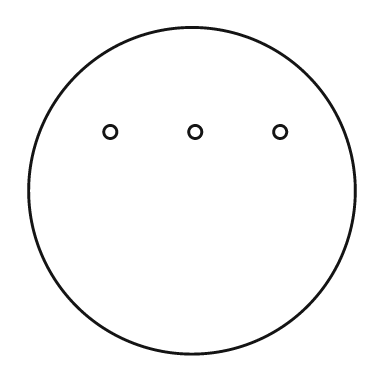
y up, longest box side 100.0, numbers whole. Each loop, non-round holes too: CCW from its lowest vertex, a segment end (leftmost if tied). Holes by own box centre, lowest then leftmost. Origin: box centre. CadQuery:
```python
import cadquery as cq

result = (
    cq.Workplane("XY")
    .moveTo(0.0, 0.0)
    .circle(50.0)
    .moveTo(-25.0, 18.0)
    .circle(2.0)
    .moveTo(1.0, 18.0)
    .circle(2.0)
    .moveTo(27.0, 18.0)
    .circle(2.0)
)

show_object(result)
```